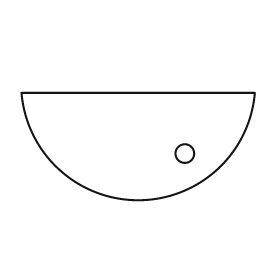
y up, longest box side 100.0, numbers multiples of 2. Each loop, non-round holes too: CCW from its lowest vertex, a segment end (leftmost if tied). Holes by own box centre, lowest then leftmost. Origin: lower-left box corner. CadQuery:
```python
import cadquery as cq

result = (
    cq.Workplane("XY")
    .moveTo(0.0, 46.0)
    .threePointArc((50.0, 0.0), (100.0, 46.0))
    .close()
    .moveTo(70.0, 20.0)
    .circle(4.0)
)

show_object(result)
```